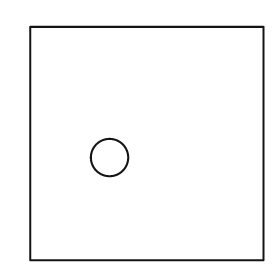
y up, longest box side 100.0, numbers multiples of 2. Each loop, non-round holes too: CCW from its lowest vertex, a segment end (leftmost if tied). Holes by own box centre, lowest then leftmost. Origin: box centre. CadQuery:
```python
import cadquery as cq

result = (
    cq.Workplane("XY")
    .moveTo(-50.0, -50.0)
    .lineTo(50.0, -50.0)
    .lineTo(50.0, 50.0)
    .lineTo(-50.0, 50.0)
    .close()
    .moveTo(-16.0, -6.0)
    .circle(8.0)
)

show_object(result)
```